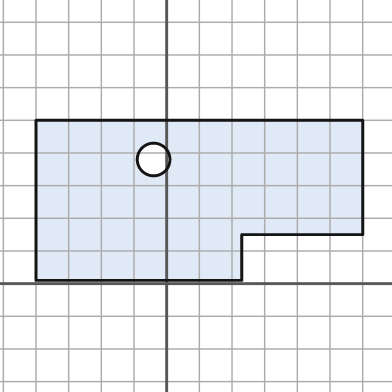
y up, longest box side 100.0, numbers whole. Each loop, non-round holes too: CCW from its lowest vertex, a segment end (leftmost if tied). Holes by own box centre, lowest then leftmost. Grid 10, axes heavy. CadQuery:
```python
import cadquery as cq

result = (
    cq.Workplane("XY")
    .moveTo(-40.0, 1.0)
    .lineTo(23.0, 1.0)
    .lineTo(23.0, 15.0)
    .lineTo(60.0, 15.0)
    .lineTo(60.0, 50.0)
    .lineTo(-40.0, 50.0)
    .close()
    .moveTo(-4.0, 38.0)
    .circle(5.0)
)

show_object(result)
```